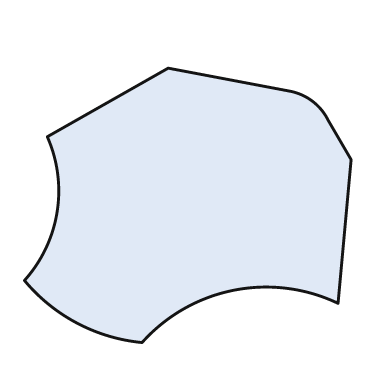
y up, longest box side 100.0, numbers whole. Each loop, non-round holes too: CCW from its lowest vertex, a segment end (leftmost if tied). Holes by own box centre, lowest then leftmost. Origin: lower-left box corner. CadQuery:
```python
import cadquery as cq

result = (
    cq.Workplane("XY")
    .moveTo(36.0, 0.0)
    .threePointArc((64.0, 16.0), (96.0, 12.0))
    .lineTo(100.0, 56.0)
    .lineTo(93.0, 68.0)
    .threePointArc((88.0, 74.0), (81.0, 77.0))
    .lineTo(44.0, 84.0)
    .lineTo(7.0, 63.0)
    .threePointArc((10.0, 40.0), (0.0, 19.0))
    .threePointArc((16.0, 6.0), (36.0, 0.0))
    .close()
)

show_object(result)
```